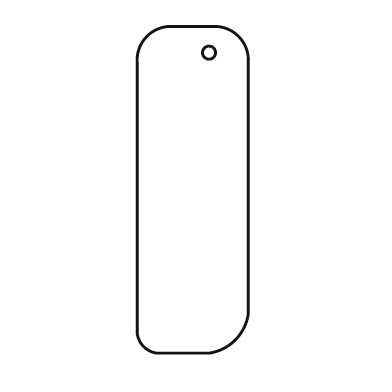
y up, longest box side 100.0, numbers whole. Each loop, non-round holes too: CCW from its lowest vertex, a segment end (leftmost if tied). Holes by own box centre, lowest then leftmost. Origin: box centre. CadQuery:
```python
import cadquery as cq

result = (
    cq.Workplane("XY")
    .moveTo(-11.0, -50.0)
    .lineTo(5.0, -50.0)
    .threePointArc((13.0, -46.0), (17.0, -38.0))
    .lineTo(17.0, 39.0)
    .threePointArc((14.0, 47.0), (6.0, 50.0))
    .lineTo(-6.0, 50.0)
    .threePointArc((-14.0, 47.0), (-17.0, 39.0))
    .lineTo(-17.0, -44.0)
    .threePointArc((-15.0, -48.0), (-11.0, -50.0))
    .close()
    .moveTo(5.0, 42.0)
    .circle(2.0)
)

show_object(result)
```